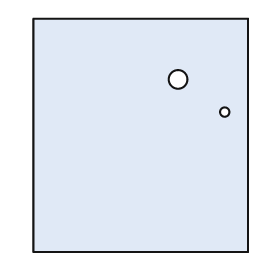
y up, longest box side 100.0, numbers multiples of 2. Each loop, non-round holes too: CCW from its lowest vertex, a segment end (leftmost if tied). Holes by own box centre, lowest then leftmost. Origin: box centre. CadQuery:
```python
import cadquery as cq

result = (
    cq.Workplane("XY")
    .moveTo(-46.0, -50.0)
    .lineTo(46.0, -50.0)
    .lineTo(46.0, 50.0)
    .lineTo(-46.0, 50.0)
    .close()
    .moveTo(36.0, 10.0)
    .circle(2.0)
    .moveTo(16.0, 24.0)
    .circle(4.0)
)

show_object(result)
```